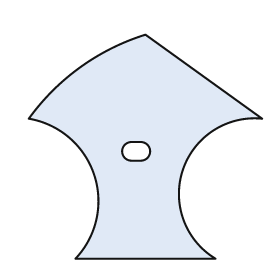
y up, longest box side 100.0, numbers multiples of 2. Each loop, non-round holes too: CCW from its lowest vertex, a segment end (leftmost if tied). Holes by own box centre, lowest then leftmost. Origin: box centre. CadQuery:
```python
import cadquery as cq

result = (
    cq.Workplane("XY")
    .moveTo(-30.0, -48.0)
    .lineTo(30.0, -48.0)
    .threePointArc((16.0, -10.0), (50.0, 12.0))
    .lineTo(0.0, 48.0)
    .threePointArc((-28.0, 34.0), (-50.0, 12.0))
    .threePointArc((-22.0, -12.0), (-30.0, -48.0))
    .close()
    .moveTo(-6.0, -6.0)
    .lineTo(-2.0, -6.0)
    .threePointArc((2.0, -2.0), (-2.0, 2.0))
    .lineTo(-6.0, 2.0)
    .threePointArc((-10.0, -2.0), (-6.0, -6.0))
    .close()
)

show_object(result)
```